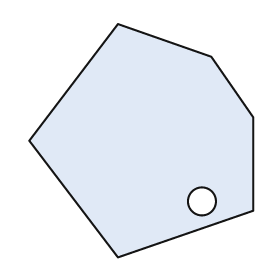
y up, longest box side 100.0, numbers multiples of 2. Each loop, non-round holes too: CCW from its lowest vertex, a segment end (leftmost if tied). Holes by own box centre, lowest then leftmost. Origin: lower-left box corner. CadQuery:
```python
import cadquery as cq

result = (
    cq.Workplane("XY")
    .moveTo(38.0, 0.0)
    .lineTo(96.0, 20.0)
    .lineTo(96.0, 60.0)
    .lineTo(78.0, 86.0)
    .lineTo(38.0, 100.0)
    .lineTo(0.0, 50.0)
    .close()
    .moveTo(74.0, 24.0)
    .circle(6.0)
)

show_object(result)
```